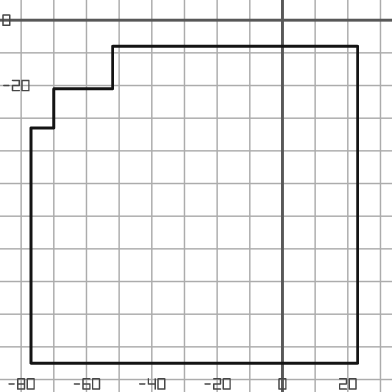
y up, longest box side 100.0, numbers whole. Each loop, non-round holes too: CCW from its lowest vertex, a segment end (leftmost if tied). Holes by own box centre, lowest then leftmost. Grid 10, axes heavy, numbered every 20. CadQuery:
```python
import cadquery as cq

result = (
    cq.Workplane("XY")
    .moveTo(-77.0, -105.0)
    .lineTo(23.0, -105.0)
    .lineTo(23.0, -8.0)
    .lineTo(-52.0, -8.0)
    .lineTo(-52.0, -21.0)
    .lineTo(-70.0, -21.0)
    .lineTo(-70.0, -33.0)
    .lineTo(-77.0, -33.0)
    .close()
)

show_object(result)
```